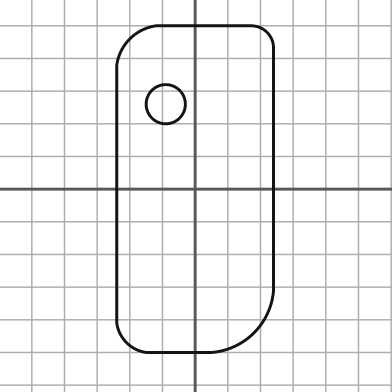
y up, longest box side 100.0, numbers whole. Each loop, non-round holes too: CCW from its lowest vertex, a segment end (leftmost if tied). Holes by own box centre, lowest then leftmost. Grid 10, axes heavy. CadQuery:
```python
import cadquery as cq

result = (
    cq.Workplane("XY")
    .moveTo(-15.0, -50.0)
    .lineTo(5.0, -50.0)
    .threePointArc((18.0, -44.0), (24.0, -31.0))
    .lineTo(24.0, 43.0)
    .threePointArc((22.0, 48.0), (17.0, 50.0))
    .lineTo(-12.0, 50.0)
    .threePointArc((-20.0, 46.0), (-24.0, 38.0))
    .lineTo(-24.0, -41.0)
    .threePointArc((-21.0, -47.0), (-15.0, -50.0))
    .close()
    .moveTo(-9.0, 26.0)
    .circle(6.0)
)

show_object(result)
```